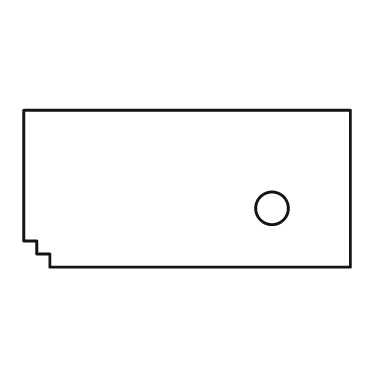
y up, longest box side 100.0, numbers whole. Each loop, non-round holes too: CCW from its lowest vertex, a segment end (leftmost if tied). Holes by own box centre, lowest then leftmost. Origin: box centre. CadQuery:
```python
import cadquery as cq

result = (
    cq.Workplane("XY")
    .moveTo(-42.0, -24.0)
    .lineTo(50.0, -24.0)
    .lineTo(50.0, 24.0)
    .lineTo(-50.0, 24.0)
    .lineTo(-50.0, -16.0)
    .lineTo(-46.0, -16.0)
    .lineTo(-46.0, -20.0)
    .lineTo(-42.0, -20.0)
    .close()
    .moveTo(26.0, -6.0)
    .circle(5.0)
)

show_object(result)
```